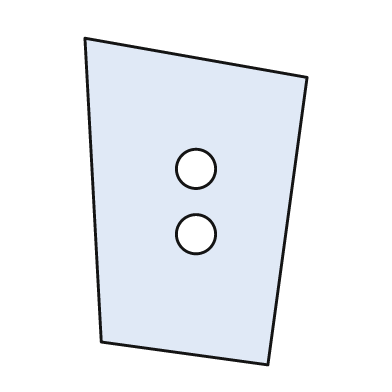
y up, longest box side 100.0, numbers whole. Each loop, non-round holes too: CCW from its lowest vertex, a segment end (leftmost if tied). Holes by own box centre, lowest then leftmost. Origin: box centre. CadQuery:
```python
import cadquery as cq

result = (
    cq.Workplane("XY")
    .moveTo(22.0, -50.0)
    .lineTo(34.0, 38.0)
    .lineTo(-34.0, 50.0)
    .lineTo(-29.0, -43.0)
    .close()
    .moveTo(0.0, -10.0)
    .circle(6.0)
    .moveTo(0.0, 10.0)
    .circle(6.0)
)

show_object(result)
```